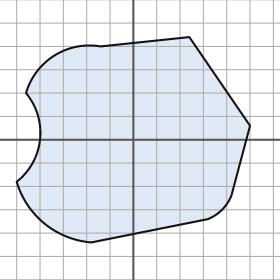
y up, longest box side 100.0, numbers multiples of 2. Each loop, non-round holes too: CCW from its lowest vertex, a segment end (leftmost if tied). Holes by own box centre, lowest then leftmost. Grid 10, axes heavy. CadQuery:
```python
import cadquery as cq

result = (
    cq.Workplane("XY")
    .moveTo(-18.0, -44.0)
    .lineTo(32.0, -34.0)
    .threePointArc((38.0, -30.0), (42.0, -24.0))
    .lineTo(50.0, 6.0)
    .lineTo(24.0, 44.0)
    .lineTo(-14.0, 40.0)
    .threePointArc((-34.0, 36.0), (-46.0, 20.0))
    .threePointArc((-40.0, 0.0), (-50.0, -18.0))
    .threePointArc((-38.0, -36.0), (-18.0, -44.0))
    .close()
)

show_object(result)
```